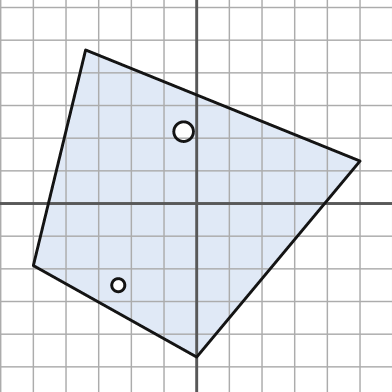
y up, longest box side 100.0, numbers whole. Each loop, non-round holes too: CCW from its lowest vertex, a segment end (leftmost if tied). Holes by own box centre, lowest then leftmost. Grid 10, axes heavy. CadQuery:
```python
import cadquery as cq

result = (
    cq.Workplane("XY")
    .moveTo(0.0, -47.0)
    .lineTo(50.0, 13.0)
    .lineTo(-34.0, 47.0)
    .lineTo(-50.0, -19.0)
    .close()
    .moveTo(-24.0, -25.0)
    .circle(2.0)
    .moveTo(-4.0, 22.0)
    .circle(3.0)
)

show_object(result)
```